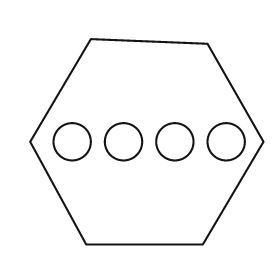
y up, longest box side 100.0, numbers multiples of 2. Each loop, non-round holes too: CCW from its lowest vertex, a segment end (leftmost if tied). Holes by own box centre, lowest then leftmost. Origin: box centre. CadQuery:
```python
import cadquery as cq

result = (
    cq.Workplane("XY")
    .moveTo(-26.0, -44.0)
    .lineTo(24.0, -44.0)
    .lineTo(50.0, 0.0)
    .lineTo(26.0, 42.0)
    .lineTo(-24.0, 44.0)
    .lineTo(-50.0, 0.0)
    .close()
    .moveTo(-32.0, 0.0)
    .circle(8.0)
    .moveTo(-10.0, 0.0)
    .circle(8.0)
    .moveTo(12.0, 0.0)
    .circle(8.0)
    .moveTo(34.0, 0.0)
    .circle(8.0)
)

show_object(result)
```